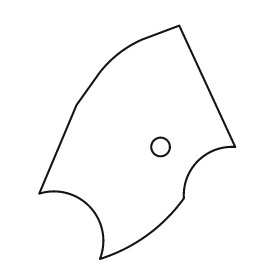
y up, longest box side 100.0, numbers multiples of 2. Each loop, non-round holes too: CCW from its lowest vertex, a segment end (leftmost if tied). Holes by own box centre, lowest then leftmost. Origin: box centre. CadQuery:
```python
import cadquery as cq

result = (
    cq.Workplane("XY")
    .moveTo(-16.0, -50.0)
    .threePointArc((4.0, -40.0), (20.0, -24.0))
    .threePointArc((26.0, -8.0), (42.0, -2.0))
    .lineTo(18.0, 50.0)
    .lineTo(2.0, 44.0)
    .threePointArc((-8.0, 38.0), (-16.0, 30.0))
    .lineTo(-26.0, 16.0)
    .lineTo(-42.0, -22.0)
    .threePointArc((-20.0, -28.0), (-16.0, -50.0))
    .close()
    .moveTo(10.0, -2.0)
    .circle(4.0)
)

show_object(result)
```